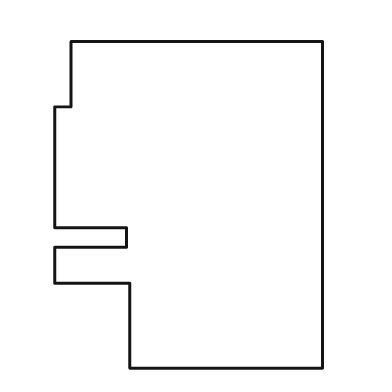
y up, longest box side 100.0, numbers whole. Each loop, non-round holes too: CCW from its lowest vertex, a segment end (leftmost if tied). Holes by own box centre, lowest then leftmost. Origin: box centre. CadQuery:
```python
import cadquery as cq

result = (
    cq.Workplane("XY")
    .moveTo(-18.0, -50.0)
    .lineTo(41.0, -50.0)
    .lineTo(41.0, 50.0)
    .lineTo(-36.0, 50.0)
    .lineTo(-36.0, 30.0)
    .lineTo(-41.0, 30.0)
    .lineTo(-41.0, -7.0)
    .lineTo(-19.0, -7.0)
    .lineTo(-19.0, -13.0)
    .lineTo(-41.0, -13.0)
    .lineTo(-41.0, -24.0)
    .lineTo(-18.0, -24.0)
    .close()
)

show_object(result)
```